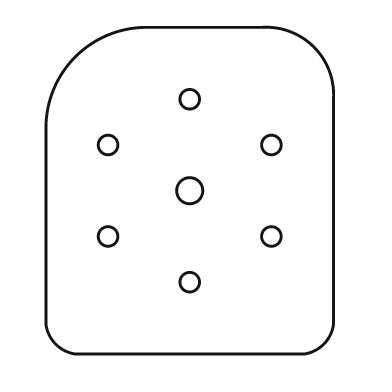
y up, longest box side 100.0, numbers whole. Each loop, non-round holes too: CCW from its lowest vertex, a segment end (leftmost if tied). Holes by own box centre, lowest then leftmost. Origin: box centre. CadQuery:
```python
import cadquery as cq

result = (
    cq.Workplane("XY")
    .moveTo(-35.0, -50.0)
    .lineTo(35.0, -50.0)
    .threePointArc((41.0, -47.0), (44.0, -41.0))
    .lineTo(44.0, 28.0)
    .threePointArc((38.0, 44.0), (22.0, 50.0))
    .lineTo(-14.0, 50.0)
    .threePointArc((-35.0, 41.0), (-44.0, 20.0))
    .lineTo(-44.0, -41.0)
    .threePointArc((-41.0, -47.0), (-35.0, -50.0))
    .close()
    .moveTo(0.0, -28.0)
    .circle(3.0)
    .moveTo(-25.0, -14.0)
    .circle(3.0)
    .moveTo(25.0, -14.0)
    .circle(3.0)
    .moveTo(0.0, 0.0)
    .circle(4.0)
    .moveTo(-25.0, 14.0)
    .circle(3.0)
    .moveTo(25.0, 14.0)
    .circle(3.0)
    .moveTo(0.0, 28.0)
    .circle(3.0)
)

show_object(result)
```